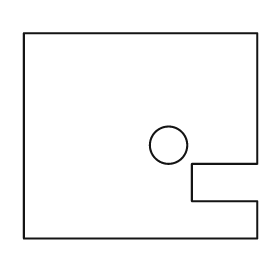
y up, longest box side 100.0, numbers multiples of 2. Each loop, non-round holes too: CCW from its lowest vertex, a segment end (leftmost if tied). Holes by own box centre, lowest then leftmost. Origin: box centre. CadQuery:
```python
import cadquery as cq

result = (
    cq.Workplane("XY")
    .moveTo(-50.0, -44.0)
    .lineTo(50.0, -44.0)
    .lineTo(50.0, -28.0)
    .lineTo(22.0, -28.0)
    .lineTo(22.0, -12.0)
    .lineTo(50.0, -12.0)
    .lineTo(50.0, 44.0)
    .lineTo(-50.0, 44.0)
    .close()
    .moveTo(12.0, -4.0)
    .circle(8.0)
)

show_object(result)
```